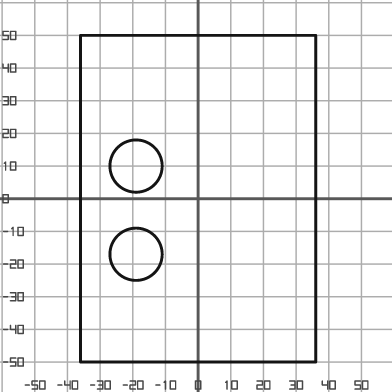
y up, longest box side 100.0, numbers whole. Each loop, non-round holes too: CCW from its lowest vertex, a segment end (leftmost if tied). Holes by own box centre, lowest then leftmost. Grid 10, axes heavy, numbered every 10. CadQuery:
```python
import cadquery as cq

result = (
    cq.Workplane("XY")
    .moveTo(-36.0, -50.0)
    .lineTo(36.0, -50.0)
    .lineTo(36.0, 50.0)
    .lineTo(-36.0, 50.0)
    .close()
    .moveTo(-19.0, -17.0)
    .circle(8.0)
    .moveTo(-19.0, 10.0)
    .circle(8.0)
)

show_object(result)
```